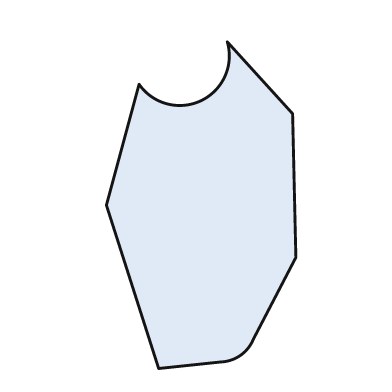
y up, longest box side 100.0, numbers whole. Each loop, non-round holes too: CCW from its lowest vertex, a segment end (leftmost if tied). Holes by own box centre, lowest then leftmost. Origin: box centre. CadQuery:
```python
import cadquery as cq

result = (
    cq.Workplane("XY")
    .moveTo(-13.0, -50.0)
    .lineTo(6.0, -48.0)
    .threePointArc((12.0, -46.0), (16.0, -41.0))
    .lineTo(29.0, -16.0)
    .lineTo(28.0, 28.0)
    .lineTo(8.0, 50.0)
    .threePointArc((0.0, 32.0), (-19.0, 37.0))
    .lineTo(-29.0, 0.0)
    .close()
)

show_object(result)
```